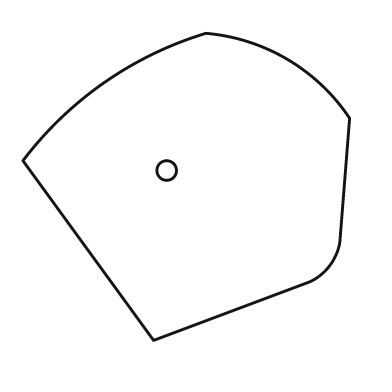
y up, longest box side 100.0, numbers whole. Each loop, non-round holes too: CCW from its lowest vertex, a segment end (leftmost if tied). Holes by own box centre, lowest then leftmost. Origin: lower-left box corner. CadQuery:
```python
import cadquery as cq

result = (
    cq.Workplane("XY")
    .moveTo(40.0, 0.0)
    .lineTo(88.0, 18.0)
    .threePointArc((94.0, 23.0), (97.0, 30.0))
    .lineTo(100.0, 68.0)
    .threePointArc((81.0, 86.0), (56.0, 94.0))
    .threePointArc((25.0, 79.0), (0.0, 55.0))
    .close()
    .moveTo(44.0, 52.0)
    .circle(3.0)
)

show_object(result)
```